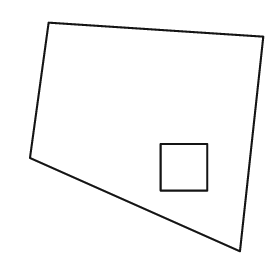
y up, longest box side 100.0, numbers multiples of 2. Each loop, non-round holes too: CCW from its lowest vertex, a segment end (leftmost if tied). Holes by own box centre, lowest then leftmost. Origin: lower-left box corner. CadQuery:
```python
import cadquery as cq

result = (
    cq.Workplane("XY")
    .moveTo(90.0, 0.0)
    .lineTo(100.0, 92.0)
    .lineTo(8.0, 98.0)
    .lineTo(0.0, 40.0)
    .close()
    .moveTo(56.0, 26.0)
    .lineTo(76.0, 26.0)
    .lineTo(76.0, 46.0)
    .lineTo(56.0, 46.0)
    .close()
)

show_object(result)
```